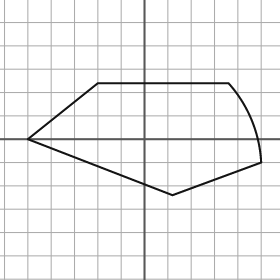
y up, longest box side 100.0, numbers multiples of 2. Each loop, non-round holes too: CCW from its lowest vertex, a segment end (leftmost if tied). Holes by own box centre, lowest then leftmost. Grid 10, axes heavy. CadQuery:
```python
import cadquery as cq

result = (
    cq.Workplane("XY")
    .moveTo(12.0, -24.0)
    .lineTo(50.0, -10.0)
    .threePointArc((46.0, 8.0), (36.0, 24.0))
    .lineTo(-20.0, 24.0)
    .lineTo(-50.0, 0.0)
    .close()
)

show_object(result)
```